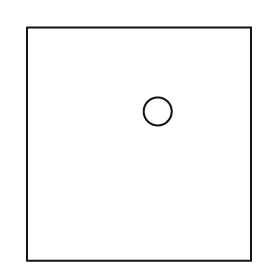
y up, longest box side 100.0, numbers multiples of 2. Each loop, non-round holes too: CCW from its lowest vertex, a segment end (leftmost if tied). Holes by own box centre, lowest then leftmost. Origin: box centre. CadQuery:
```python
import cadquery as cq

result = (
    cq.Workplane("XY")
    .moveTo(-48.0, -50.0)
    .lineTo(48.0, -50.0)
    .lineTo(48.0, 50.0)
    .lineTo(-48.0, 50.0)
    .close()
    .moveTo(8.0, 14.0)
    .circle(6.0)
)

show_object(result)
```